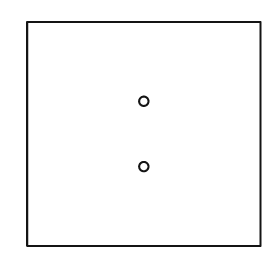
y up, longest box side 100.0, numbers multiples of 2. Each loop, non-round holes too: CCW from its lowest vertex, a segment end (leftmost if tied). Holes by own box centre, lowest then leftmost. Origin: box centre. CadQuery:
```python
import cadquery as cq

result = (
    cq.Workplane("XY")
    .moveTo(-50.0, -48.0)
    .lineTo(50.0, -48.0)
    .lineTo(50.0, 48.0)
    .lineTo(-50.0, 48.0)
    .close()
    .moveTo(0.0, -14.0)
    .circle(2.0)
    .moveTo(0.0, 14.0)
    .circle(2.0)
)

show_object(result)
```